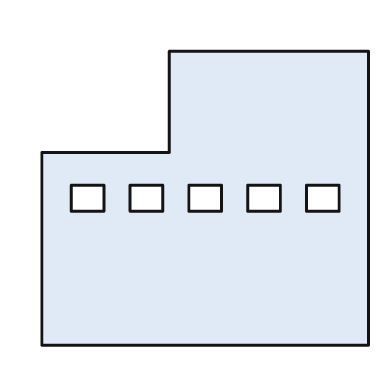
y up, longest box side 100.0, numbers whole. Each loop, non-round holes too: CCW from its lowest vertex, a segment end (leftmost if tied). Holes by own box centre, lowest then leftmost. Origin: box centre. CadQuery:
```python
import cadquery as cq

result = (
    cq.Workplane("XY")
    .moveTo(-50.0, -45.0)
    .lineTo(50.0, -45.0)
    .lineTo(50.0, 45.0)
    .lineTo(-11.0, 45.0)
    .lineTo(-11.0, 14.0)
    .lineTo(-50.0, 14.0)
    .close()
    .moveTo(-41.0, -4.0)
    .lineTo(-31.0, -4.0)
    .lineTo(-31.0, 4.0)
    .lineTo(-41.0, 4.0)
    .close()
    .moveTo(-23.0, -4.0)
    .lineTo(-13.0, -4.0)
    .lineTo(-13.0, 4.0)
    .lineTo(-23.0, 4.0)
    .close()
    .moveTo(-5.0, -4.0)
    .lineTo(5.0, -4.0)
    .lineTo(5.0, 4.0)
    .lineTo(-5.0, 4.0)
    .close()
    .moveTo(13.0, -4.0)
    .lineTo(23.0, -4.0)
    .lineTo(23.0, 4.0)
    .lineTo(13.0, 4.0)
    .close()
    .moveTo(31.0, -4.0)
    .lineTo(41.0, -4.0)
    .lineTo(41.0, 4.0)
    .lineTo(31.0, 4.0)
    .close()
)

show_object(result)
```